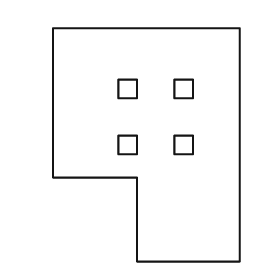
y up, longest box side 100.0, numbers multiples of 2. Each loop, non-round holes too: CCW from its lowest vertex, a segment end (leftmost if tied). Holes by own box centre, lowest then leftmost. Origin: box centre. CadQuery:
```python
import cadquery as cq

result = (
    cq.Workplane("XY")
    .moveTo(-4.0, -50.0)
    .lineTo(40.0, -50.0)
    .lineTo(40.0, 50.0)
    .lineTo(-40.0, 50.0)
    .lineTo(-40.0, -14.0)
    .lineTo(-4.0, -14.0)
    .close()
    .moveTo(-12.0, -4.0)
    .lineTo(-4.0, -4.0)
    .lineTo(-4.0, 4.0)
    .lineTo(-12.0, 4.0)
    .close()
    .moveTo(12.0, -4.0)
    .lineTo(20.0, -4.0)
    .lineTo(20.0, 4.0)
    .lineTo(12.0, 4.0)
    .close()
    .moveTo(-12.0, 20.0)
    .lineTo(-4.0, 20.0)
    .lineTo(-4.0, 28.0)
    .lineTo(-12.0, 28.0)
    .close()
    .moveTo(12.0, 20.0)
    .lineTo(20.0, 20.0)
    .lineTo(20.0, 28.0)
    .lineTo(12.0, 28.0)
    .close()
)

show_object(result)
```